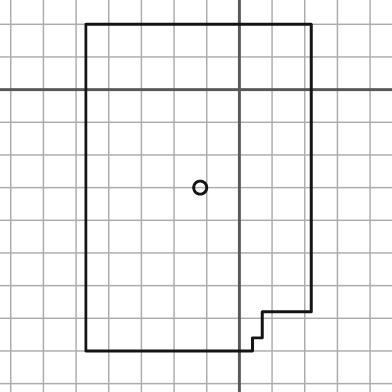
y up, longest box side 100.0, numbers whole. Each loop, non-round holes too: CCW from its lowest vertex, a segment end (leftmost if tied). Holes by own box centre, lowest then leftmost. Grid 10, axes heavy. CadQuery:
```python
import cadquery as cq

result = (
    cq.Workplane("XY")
    .moveTo(-47.0, -80.0)
    .lineTo(4.0, -80.0)
    .lineTo(4.0, -76.0)
    .lineTo(7.0, -76.0)
    .lineTo(7.0, -68.0)
    .lineTo(22.0, -68.0)
    .lineTo(22.0, 20.0)
    .lineTo(-47.0, 20.0)
    .close()
    .moveTo(-12.0, -30.0)
    .circle(2.0)
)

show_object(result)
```